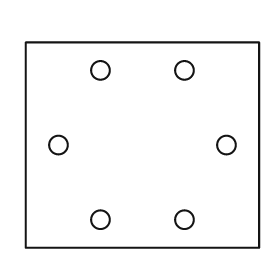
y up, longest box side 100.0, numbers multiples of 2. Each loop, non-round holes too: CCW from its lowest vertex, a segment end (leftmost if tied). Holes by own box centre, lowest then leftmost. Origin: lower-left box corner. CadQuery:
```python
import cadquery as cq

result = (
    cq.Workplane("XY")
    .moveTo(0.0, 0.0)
    .lineTo(100.0, 0.0)
    .lineTo(100.0, 88.0)
    .lineTo(0.0, 88.0)
    .close()
    .moveTo(32.0, 12.0)
    .circle(4.0)
    .moveTo(68.0, 12.0)
    .circle(4.0)
    .moveTo(14.0, 44.0)
    .circle(4.0)
    .moveTo(86.0, 44.0)
    .circle(4.0)
    .moveTo(32.0, 76.0)
    .circle(4.0)
    .moveTo(68.0, 76.0)
    .circle(4.0)
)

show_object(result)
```